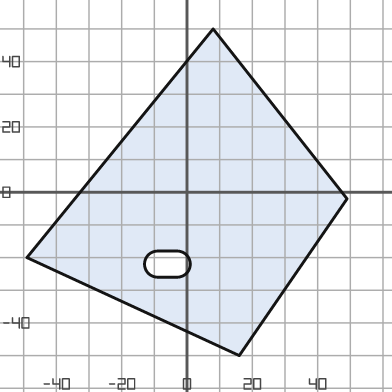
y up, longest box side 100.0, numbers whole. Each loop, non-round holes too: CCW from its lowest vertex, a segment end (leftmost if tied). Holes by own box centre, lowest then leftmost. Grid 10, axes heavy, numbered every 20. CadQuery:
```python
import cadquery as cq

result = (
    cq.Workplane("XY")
    .moveTo(16.0, -50.0)
    .lineTo(49.0, -2.0)
    .lineTo(8.0, 50.0)
    .lineTo(-49.0, -20.0)
    .close()
    .moveTo(-9.0, -26.0)
    .lineTo(-3.0, -26.0)
    .threePointArc((1.0, -22.0), (-3.0, -18.0))
    .lineTo(-9.0, -18.0)
    .threePointArc((-13.0, -22.0), (-9.0, -26.0))
    .close()
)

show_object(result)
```